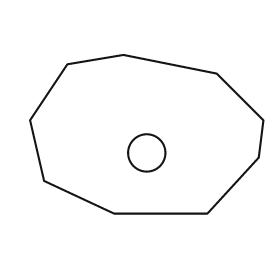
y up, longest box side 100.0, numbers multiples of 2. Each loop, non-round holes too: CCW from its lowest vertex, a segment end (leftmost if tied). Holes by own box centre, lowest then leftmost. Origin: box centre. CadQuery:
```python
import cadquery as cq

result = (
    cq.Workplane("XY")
    .moveTo(-14.0, -34.0)
    .lineTo(26.0, -34.0)
    .lineTo(48.0, -10.0)
    .lineTo(50.0, 6.0)
    .lineTo(30.0, 26.0)
    .lineTo(-10.0, 34.0)
    .lineTo(-34.0, 30.0)
    .lineTo(-50.0, 6.0)
    .lineTo(-44.0, -20.0)
    .close()
    .moveTo(0.0, -8.0)
    .circle(8.0)
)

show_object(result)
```